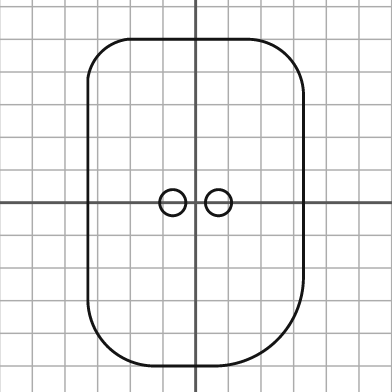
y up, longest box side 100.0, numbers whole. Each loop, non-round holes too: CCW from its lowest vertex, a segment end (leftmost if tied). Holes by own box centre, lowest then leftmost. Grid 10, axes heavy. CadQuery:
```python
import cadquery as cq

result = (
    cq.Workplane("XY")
    .moveTo(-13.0, -50.0)
    .lineTo(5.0, -50.0)
    .threePointArc((25.0, -42.0), (33.0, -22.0))
    .lineTo(33.0, 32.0)
    .threePointArc((28.0, 45.0), (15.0, 50.0))
    .lineTo(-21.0, 50.0)
    .threePointArc((-29.0, 46.0), (-33.0, 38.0))
    .lineTo(-33.0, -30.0)
    .threePointArc((-27.0, -44.0), (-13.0, -50.0))
    .close()
    .moveTo(-7.0, 0.0)
    .circle(4.0)
    .moveTo(7.0, 0.0)
    .circle(4.0)
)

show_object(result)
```